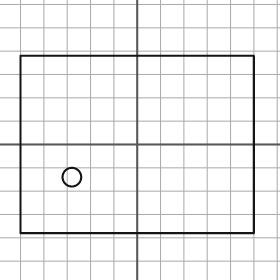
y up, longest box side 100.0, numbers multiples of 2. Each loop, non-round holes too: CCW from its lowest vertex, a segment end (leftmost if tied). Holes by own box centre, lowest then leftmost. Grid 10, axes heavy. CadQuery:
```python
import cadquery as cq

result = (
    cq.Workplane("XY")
    .moveTo(-50.0, -38.0)
    .lineTo(50.0, -38.0)
    .lineTo(50.0, 38.0)
    .lineTo(-50.0, 38.0)
    .close()
    .moveTo(-28.0, -14.0)
    .circle(4.0)
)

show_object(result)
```